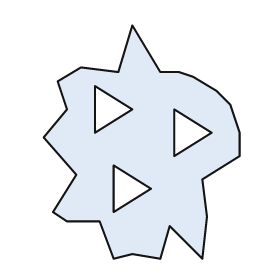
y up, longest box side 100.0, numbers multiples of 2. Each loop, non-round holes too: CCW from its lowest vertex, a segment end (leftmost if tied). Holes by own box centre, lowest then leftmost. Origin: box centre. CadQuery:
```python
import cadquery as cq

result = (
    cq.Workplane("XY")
    .moveTo(-12.0, -50.0)
    .lineTo(-4.0, -48.0)
    .lineTo(8.0, -50.0)
    .lineTo(12.0, -36.0)
    .lineTo(26.0, -50.0)
    .lineTo(28.0, -32.0)
    .lineTo(26.0, -16.0)
    .lineTo(42.0, -6.0)
    .lineTo(42.0, 4.0)
    .lineTo(38.0, 16.0)
    .lineTo(32.0, 22.0)
    .lineTo(22.0, 28.0)
    .lineTo(16.0, 30.0)
    .lineTo(8.0, 30.0)
    .lineTo(-4.0, 50.0)
    .lineTo(-10.0, 30.0)
    .lineTo(-26.0, 32.0)
    .lineTo(-36.0, 26.0)
    .lineTo(-32.0, 14.0)
    .lineTo(-42.0, 2.0)
    .lineTo(-28.0, -14.0)
    .lineTo(-38.0, -30.0)
    .lineTo(-32.0, -34.0)
    .lineTo(-18.0, -34.0)
    .close()
    .moveTo(-12.0, -30.0)
    .lineTo(4.0, -20.0)
    .lineTo(-12.0, -10.0)
    .close()
    .moveTo(14.0, -6.0)
    .lineTo(30.0, 4.0)
    .lineTo(14.0, 14.0)
    .close()
    .moveTo(-20.0, 4.0)
    .lineTo(-4.0, 14.0)
    .lineTo(-20.0, 24.0)
    .close()
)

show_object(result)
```